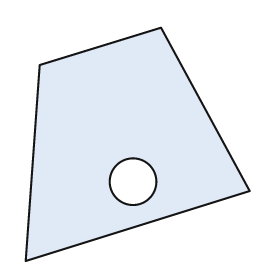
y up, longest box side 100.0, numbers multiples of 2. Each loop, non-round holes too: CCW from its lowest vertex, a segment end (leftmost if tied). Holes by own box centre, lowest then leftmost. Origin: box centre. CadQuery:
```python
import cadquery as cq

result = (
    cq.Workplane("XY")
    .moveTo(-48.0, -50.0)
    .lineTo(48.0, -20.0)
    .lineTo(10.0, 50.0)
    .lineTo(-42.0, 34.0)
    .close()
    .moveTo(-2.0, -16.0)
    .circle(10.0)
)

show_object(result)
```